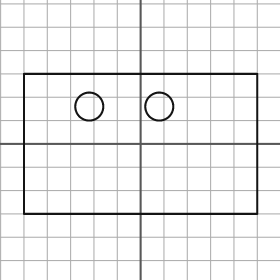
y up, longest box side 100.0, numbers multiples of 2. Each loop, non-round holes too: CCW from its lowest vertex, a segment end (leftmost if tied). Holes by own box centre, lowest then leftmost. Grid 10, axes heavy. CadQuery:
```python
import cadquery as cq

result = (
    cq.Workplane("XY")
    .moveTo(-50.0, -30.0)
    .lineTo(50.0, -30.0)
    .lineTo(50.0, 30.0)
    .lineTo(-50.0, 30.0)
    .close()
    .moveTo(-22.0, 16.0)
    .circle(6.0)
    .moveTo(8.0, 16.0)
    .circle(6.0)
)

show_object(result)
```